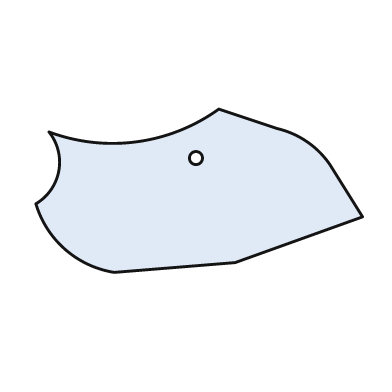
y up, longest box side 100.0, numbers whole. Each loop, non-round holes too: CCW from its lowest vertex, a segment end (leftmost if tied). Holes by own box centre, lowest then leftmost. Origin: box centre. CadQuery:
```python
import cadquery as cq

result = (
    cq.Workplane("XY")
    .moveTo(-26.0, -25.0)
    .lineTo(11.0, -22.0)
    .lineTo(50.0, -8.0)
    .lineTo(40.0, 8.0)
    .threePointArc((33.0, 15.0), (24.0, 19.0))
    .lineTo(6.0, 25.0)
    .threePointArc((-19.0, 15.0), (-46.0, 18.0))
    .threePointArc((-43.0, 6.0), (-50.0, -4.0))
    .threePointArc((-41.0, -18.0), (-26.0, -25.0))
    .close()
    .moveTo(-1.0, 10.0)
    .circle(2.0)
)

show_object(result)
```